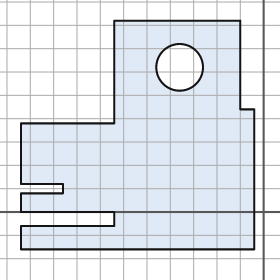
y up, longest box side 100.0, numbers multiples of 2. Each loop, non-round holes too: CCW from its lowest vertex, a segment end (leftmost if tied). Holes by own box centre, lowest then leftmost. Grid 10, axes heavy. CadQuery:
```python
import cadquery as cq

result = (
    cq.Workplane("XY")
    .moveTo(-104.0, -16.0)
    .lineTo(-4.0, -16.0)
    .lineTo(-4.0, 44.0)
    .lineTo(-10.0, 44.0)
    .lineTo(-10.0, 82.0)
    .lineTo(-64.0, 82.0)
    .lineTo(-64.0, 38.0)
    .lineTo(-104.0, 38.0)
    .lineTo(-104.0, 12.0)
    .lineTo(-86.0, 12.0)
    .lineTo(-86.0, 8.0)
    .lineTo(-104.0, 8.0)
    .lineTo(-104.0, 0.0)
    .lineTo(-64.0, 0.0)
    .lineTo(-64.0, -6.0)
    .lineTo(-104.0, -6.0)
    .close()
    .moveTo(-36.0, 62.0)
    .circle(10.0)
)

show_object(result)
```